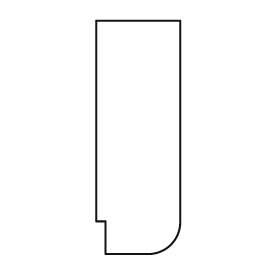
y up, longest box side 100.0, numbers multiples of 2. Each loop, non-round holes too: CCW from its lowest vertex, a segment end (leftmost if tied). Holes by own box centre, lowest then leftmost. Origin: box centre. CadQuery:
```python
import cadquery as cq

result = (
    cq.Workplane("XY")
    .moveTo(-14.0, -50.0)
    .lineTo(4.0, -50.0)
    .threePointArc((14.0, -46.0), (18.0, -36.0))
    .lineTo(18.0, 50.0)
    .lineTo(-18.0, 50.0)
    .lineTo(-18.0, -36.0)
    .lineTo(-14.0, -36.0)
    .close()
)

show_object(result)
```